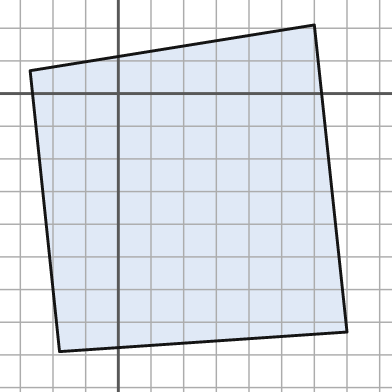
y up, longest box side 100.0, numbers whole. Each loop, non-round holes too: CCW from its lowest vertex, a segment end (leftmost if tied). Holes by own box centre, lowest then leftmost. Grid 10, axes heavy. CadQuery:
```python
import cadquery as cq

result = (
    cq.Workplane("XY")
    .moveTo(-18.0, -79.0)
    .lineTo(70.0, -73.0)
    .lineTo(60.0, 21.0)
    .lineTo(-27.0, 7.0)
    .close()
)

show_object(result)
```